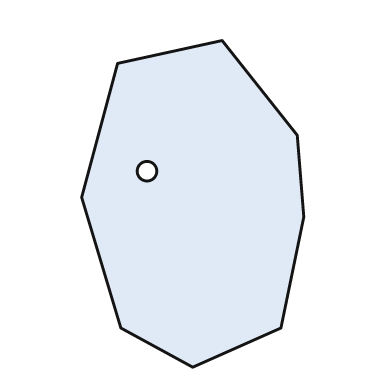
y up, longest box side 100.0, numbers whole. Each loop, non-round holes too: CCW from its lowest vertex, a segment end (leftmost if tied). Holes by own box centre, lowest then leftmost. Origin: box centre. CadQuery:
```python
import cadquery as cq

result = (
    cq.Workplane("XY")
    .moveTo(0.0, -50.0)
    .lineTo(27.0, -38.0)
    .lineTo(34.0, -4.0)
    .lineTo(32.0, 21.0)
    .lineTo(9.0, 50.0)
    .lineTo(-23.0, 43.0)
    .lineTo(-34.0, 2.0)
    .lineTo(-22.0, -38.0)
    .close()
    .moveTo(-14.0, 10.0)
    .circle(3.0)
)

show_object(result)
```